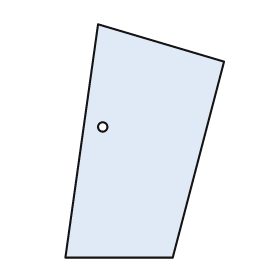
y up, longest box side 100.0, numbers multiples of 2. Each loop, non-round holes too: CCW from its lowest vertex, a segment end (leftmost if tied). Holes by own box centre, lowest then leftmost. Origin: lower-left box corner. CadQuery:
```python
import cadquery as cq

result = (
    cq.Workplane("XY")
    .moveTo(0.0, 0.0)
    .lineTo(46.0, 0.0)
    .lineTo(68.0, 84.0)
    .lineTo(14.0, 100.0)
    .close()
    .moveTo(16.0, 56.0)
    .circle(2.0)
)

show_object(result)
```